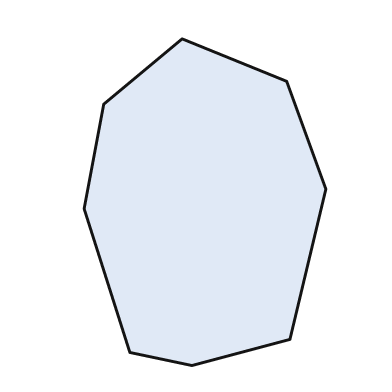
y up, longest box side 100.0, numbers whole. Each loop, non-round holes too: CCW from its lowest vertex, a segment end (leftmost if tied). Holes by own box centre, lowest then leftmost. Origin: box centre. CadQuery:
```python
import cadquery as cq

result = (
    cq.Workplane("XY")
    .moveTo(-4.0, -50.0)
    .lineTo(26.0, -42.0)
    .lineTo(37.0, 4.0)
    .lineTo(25.0, 37.0)
    .lineTo(-7.0, 50.0)
    .lineTo(-31.0, 30.0)
    .lineTo(-37.0, -2.0)
    .lineTo(-23.0, -46.0)
    .close()
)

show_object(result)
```